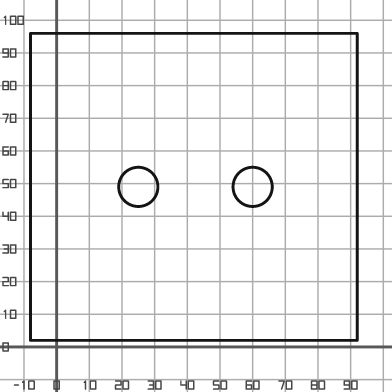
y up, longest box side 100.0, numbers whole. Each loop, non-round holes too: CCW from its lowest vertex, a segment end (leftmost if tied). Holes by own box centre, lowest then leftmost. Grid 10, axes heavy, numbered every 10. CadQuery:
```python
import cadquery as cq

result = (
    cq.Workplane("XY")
    .moveTo(-8.0, 2.0)
    .lineTo(92.0, 2.0)
    .lineTo(92.0, 96.0)
    .lineTo(-8.0, 96.0)
    .close()
    .moveTo(25.0, 49.0)
    .circle(6.0)
    .moveTo(60.0, 49.0)
    .circle(6.0)
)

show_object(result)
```